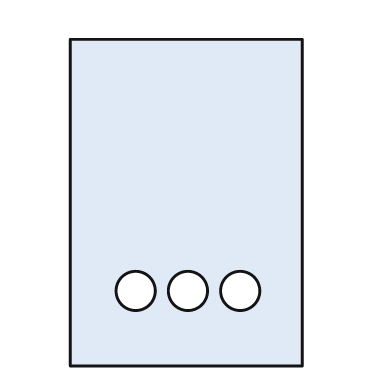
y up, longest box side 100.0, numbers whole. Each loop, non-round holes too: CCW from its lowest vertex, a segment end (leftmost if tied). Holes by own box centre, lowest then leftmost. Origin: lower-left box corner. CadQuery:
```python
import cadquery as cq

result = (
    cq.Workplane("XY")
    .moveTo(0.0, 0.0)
    .lineTo(71.0, 0.0)
    .lineTo(71.0, 100.0)
    .lineTo(0.0, 100.0)
    .close()
    .moveTo(20.0, 23.0)
    .circle(6.0)
    .moveTo(36.0, 23.0)
    .circle(6.0)
    .moveTo(52.0, 23.0)
    .circle(6.0)
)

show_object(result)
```